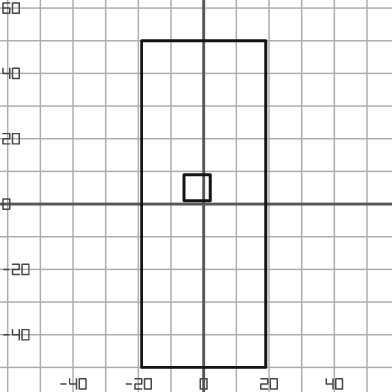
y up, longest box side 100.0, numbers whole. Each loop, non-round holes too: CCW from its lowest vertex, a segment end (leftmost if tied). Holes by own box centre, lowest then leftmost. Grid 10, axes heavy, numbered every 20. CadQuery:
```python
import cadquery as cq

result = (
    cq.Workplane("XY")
    .moveTo(-19.0, -50.0)
    .lineTo(19.0, -50.0)
    .lineTo(19.0, 50.0)
    .lineTo(-19.0, 50.0)
    .close()
    .moveTo(-6.0, 1.0)
    .lineTo(2.0, 1.0)
    .lineTo(2.0, 9.0)
    .lineTo(-6.0, 9.0)
    .close()
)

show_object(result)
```